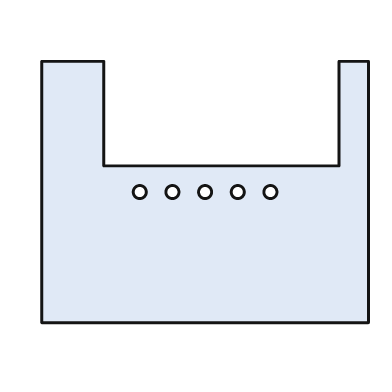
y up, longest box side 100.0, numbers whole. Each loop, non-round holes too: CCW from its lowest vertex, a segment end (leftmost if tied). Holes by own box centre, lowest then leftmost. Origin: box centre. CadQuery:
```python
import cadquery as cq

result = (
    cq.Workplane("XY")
    .moveTo(-50.0, -40.0)
    .lineTo(50.0, -40.0)
    .lineTo(50.0, 40.0)
    .lineTo(41.0, 40.0)
    .lineTo(41.0, 8.0)
    .lineTo(-31.0, 8.0)
    .lineTo(-31.0, 40.0)
    .lineTo(-50.0, 40.0)
    .close()
    .moveTo(-20.0, 0.0)
    .circle(2.0)
    .moveTo(-10.0, 0.0)
    .circle(2.0)
    .moveTo(0.0, 0.0)
    .circle(2.0)
    .moveTo(10.0, 0.0)
    .circle(2.0)
    .moveTo(20.0, 0.0)
    .circle(2.0)
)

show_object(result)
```